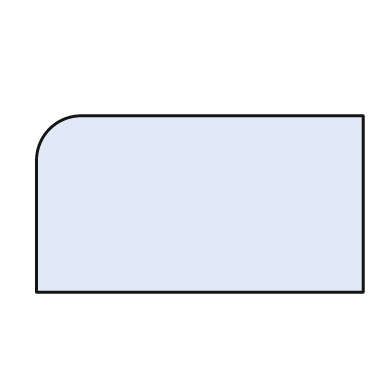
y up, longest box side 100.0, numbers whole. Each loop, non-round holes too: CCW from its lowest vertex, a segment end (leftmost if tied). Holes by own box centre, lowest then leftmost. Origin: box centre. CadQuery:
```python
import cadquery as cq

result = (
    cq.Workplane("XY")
    .moveTo(-50.0, -27.0)
    .lineTo(50.0, -27.0)
    .lineTo(50.0, 27.0)
    .lineTo(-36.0, 27.0)
    .threePointArc((-46.0, 23.0), (-50.0, 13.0))
    .close()
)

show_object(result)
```